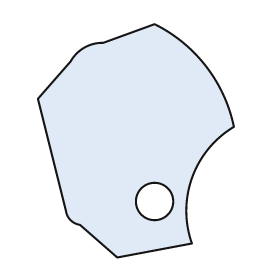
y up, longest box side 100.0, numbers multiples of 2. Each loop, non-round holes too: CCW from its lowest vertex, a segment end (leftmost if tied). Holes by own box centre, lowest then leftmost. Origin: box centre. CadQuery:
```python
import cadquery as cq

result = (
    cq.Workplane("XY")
    .moveTo(-8.0, -50.0)
    .lineTo(24.0, -44.0)
    .threePointArc((24.0, -16.0), (42.0, 6.0))
    .threePointArc((30.0, 32.0), (8.0, 50.0))
    .lineTo(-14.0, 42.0)
    .threePointArc((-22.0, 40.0), (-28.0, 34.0))
    .lineTo(-42.0, 18.0)
    .lineTo(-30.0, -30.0)
    .threePointArc((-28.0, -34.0), (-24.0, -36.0))
    .close()
    .moveTo(8.0, -26.0)
    .circle(8.0)
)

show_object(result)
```